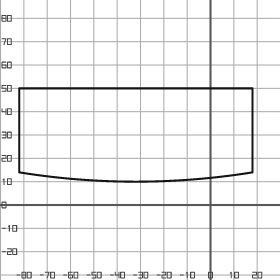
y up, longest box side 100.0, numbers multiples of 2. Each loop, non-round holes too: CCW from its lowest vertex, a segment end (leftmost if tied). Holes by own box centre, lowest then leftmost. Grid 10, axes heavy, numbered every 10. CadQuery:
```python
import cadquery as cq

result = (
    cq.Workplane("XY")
    .moveTo(-82.0, 14.0)
    .threePointArc((-32.0, 10.0), (18.0, 14.0))
    .lineTo(18.0, 50.0)
    .lineTo(-82.0, 50.0)
    .close()
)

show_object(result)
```